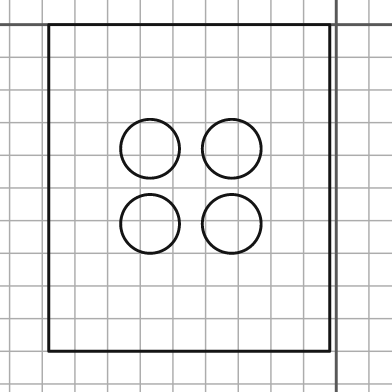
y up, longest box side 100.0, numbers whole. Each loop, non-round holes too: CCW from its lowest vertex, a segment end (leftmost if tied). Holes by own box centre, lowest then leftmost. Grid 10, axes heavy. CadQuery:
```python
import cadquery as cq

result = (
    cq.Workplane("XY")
    .moveTo(-88.0, -100.0)
    .lineTo(-2.0, -100.0)
    .lineTo(-2.0, 0.0)
    .lineTo(-88.0, 0.0)
    .close()
    .moveTo(-57.0, -61.0)
    .circle(9.0)
    .moveTo(-32.0, -61.0)
    .circle(9.0)
    .moveTo(-57.0, -38.0)
    .circle(9.0)
    .moveTo(-32.0, -38.0)
    .circle(9.0)
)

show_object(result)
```